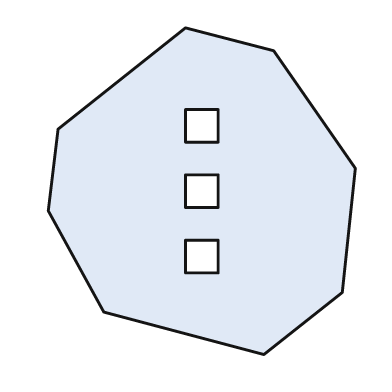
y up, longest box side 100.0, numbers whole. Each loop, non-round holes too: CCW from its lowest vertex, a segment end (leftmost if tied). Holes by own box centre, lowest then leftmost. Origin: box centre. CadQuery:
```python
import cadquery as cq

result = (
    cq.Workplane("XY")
    .moveTo(19.0, -50.0)
    .lineTo(43.0, -31.0)
    .lineTo(47.0, 7.0)
    .lineTo(22.0, 43.0)
    .lineTo(-5.0, 50.0)
    .lineTo(-44.0, 19.0)
    .lineTo(-47.0, -6.0)
    .lineTo(-30.0, -37.0)
    .close()
    .moveTo(-5.0, -25.0)
    .lineTo(5.0, -25.0)
    .lineTo(5.0, -15.0)
    .lineTo(-5.0, -15.0)
    .close()
    .moveTo(-5.0, -5.0)
    .lineTo(5.0, -5.0)
    .lineTo(5.0, 5.0)
    .lineTo(-5.0, 5.0)
    .close()
    .moveTo(-5.0, 15.0)
    .lineTo(5.0, 15.0)
    .lineTo(5.0, 25.0)
    .lineTo(-5.0, 25.0)
    .close()
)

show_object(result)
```